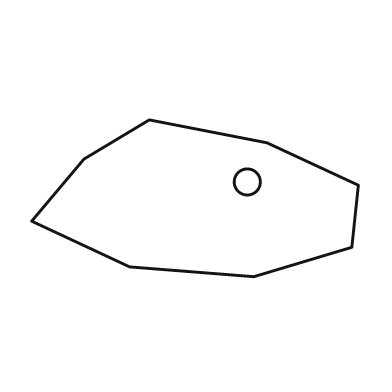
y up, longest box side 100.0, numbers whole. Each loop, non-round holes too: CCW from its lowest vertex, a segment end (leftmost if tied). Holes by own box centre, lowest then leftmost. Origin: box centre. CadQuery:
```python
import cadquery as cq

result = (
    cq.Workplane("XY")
    .moveTo(18.0, -24.0)
    .lineTo(48.0, -15.0)
    .lineTo(50.0, 4.0)
    .lineTo(22.0, 17.0)
    .lineTo(-14.0, 24.0)
    .lineTo(-34.0, 12.0)
    .lineTo(-50.0, -7.0)
    .lineTo(-20.0, -21.0)
    .close()
    .moveTo(16.0, 5.0)
    .circle(4.0)
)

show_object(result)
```